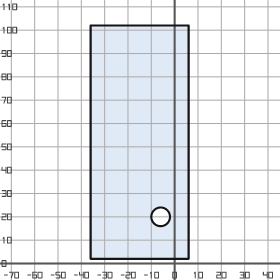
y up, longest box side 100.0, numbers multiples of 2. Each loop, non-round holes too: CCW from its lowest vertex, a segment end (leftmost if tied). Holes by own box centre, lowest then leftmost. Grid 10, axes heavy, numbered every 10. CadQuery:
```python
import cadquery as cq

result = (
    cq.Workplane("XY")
    .moveTo(-36.0, 2.0)
    .lineTo(6.0, 2.0)
    .lineTo(6.0, 102.0)
    .lineTo(-36.0, 102.0)
    .close()
    .moveTo(-6.0, 20.0)
    .circle(4.0)
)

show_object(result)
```